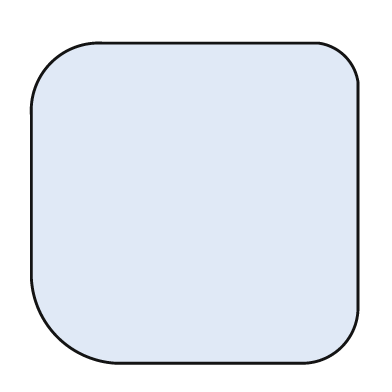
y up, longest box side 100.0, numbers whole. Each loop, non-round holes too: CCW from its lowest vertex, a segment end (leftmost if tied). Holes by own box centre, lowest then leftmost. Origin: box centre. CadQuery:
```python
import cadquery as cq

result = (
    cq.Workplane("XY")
    .moveTo(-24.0, -49.0)
    .lineTo(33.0, -49.0)
    .threePointArc((45.0, -44.0), (50.0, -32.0))
    .lineTo(50.0, 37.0)
    .threePointArc((46.0, 45.0), (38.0, 49.0))
    .lineTo(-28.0, 49.0)
    .threePointArc((-44.0, 43.0), (-50.0, 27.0))
    .lineTo(-50.0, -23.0)
    .threePointArc((-42.0, -41.0), (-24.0, -49.0))
    .close()
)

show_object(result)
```